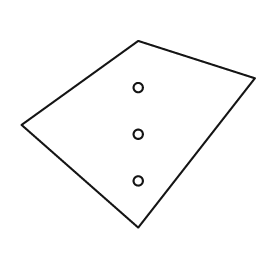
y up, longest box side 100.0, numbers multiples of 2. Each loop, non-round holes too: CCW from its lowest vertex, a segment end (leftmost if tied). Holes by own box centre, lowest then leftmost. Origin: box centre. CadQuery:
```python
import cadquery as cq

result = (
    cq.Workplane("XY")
    .moveTo(0.0, -40.0)
    .lineTo(50.0, 24.0)
    .lineTo(0.0, 40.0)
    .lineTo(-50.0, 4.0)
    .close()
    .moveTo(0.0, -20.0)
    .circle(2.0)
    .moveTo(0.0, 0.0)
    .circle(2.0)
    .moveTo(0.0, 20.0)
    .circle(2.0)
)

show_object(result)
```